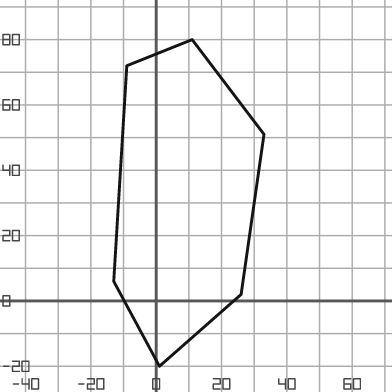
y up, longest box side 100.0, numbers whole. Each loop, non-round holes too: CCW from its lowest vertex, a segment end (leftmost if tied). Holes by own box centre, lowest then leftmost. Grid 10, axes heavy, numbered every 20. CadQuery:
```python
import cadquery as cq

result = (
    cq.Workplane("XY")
    .moveTo(1.0, -20.0)
    .lineTo(26.0, 2.0)
    .lineTo(33.0, 51.0)
    .lineTo(11.0, 80.0)
    .lineTo(-9.0, 72.0)
    .lineTo(-13.0, 6.0)
    .close()
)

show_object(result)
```